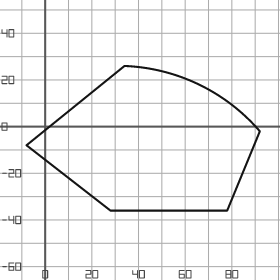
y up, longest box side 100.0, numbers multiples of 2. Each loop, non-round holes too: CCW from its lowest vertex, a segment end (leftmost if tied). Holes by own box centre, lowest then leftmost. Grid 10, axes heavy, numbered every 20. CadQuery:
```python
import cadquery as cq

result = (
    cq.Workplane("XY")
    .moveTo(28.0, -36.0)
    .lineTo(78.0, -36.0)
    .lineTo(92.0, -2.0)
    .threePointArc((66.0, 18.0), (34.0, 26.0))
    .lineTo(-8.0, -8.0)
    .close()
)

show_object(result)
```